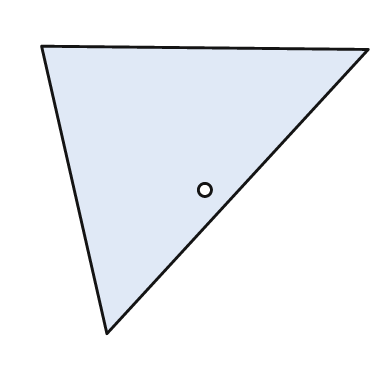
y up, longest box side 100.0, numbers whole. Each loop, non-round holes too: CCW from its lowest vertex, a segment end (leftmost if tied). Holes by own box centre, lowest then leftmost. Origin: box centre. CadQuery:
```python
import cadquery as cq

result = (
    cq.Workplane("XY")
    .moveTo(-30.0, -44.0)
    .lineTo(50.0, 43.0)
    .lineTo(-50.0, 44.0)
    .close()
    .moveTo(0.0, 0.0)
    .circle(2.0)
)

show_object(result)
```